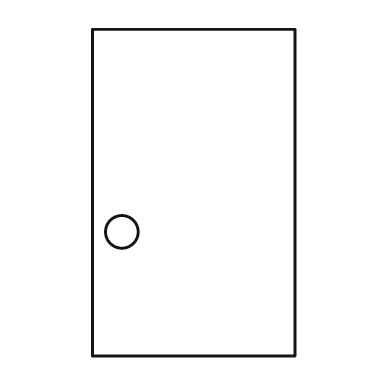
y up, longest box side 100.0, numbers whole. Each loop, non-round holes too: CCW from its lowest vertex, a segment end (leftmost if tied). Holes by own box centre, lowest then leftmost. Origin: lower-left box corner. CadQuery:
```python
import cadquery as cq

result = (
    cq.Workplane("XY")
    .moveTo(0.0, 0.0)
    .lineTo(62.0, 0.0)
    .lineTo(62.0, 100.0)
    .lineTo(0.0, 100.0)
    .close()
    .moveTo(9.0, 38.0)
    .circle(5.0)
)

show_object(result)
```